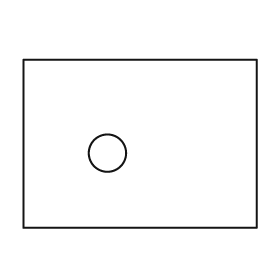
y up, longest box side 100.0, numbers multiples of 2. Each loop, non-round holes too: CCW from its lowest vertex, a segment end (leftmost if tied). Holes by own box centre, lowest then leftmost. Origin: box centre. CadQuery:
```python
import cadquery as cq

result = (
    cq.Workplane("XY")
    .moveTo(-50.0, -36.0)
    .lineTo(50.0, -36.0)
    .lineTo(50.0, 36.0)
    .lineTo(-50.0, 36.0)
    .close()
    .moveTo(-14.0, -4.0)
    .circle(8.0)
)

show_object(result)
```